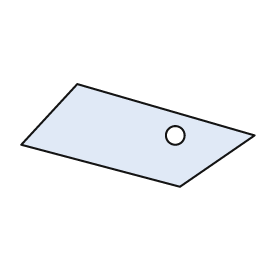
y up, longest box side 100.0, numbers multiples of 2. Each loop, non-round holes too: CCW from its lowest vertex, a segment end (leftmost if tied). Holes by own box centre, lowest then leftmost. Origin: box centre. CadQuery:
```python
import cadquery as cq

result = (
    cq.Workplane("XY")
    .moveTo(18.0, -22.0)
    .lineTo(50.0, 0.0)
    .lineTo(-26.0, 22.0)
    .lineTo(-50.0, -4.0)
    .close()
    .moveTo(16.0, 0.0)
    .circle(4.0)
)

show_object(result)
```